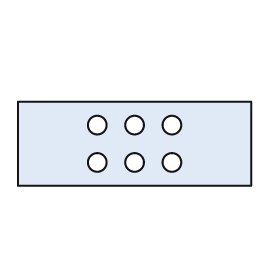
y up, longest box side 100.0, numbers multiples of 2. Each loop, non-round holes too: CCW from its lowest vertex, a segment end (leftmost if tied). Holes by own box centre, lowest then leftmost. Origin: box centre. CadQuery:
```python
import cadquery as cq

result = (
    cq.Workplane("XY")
    .moveTo(-50.0, -18.0)
    .lineTo(50.0, -18.0)
    .lineTo(50.0, 18.0)
    .lineTo(-50.0, 18.0)
    .close()
    .moveTo(-16.0, -8.0)
    .circle(4.0)
    .moveTo(0.0, -8.0)
    .circle(4.0)
    .moveTo(16.0, -8.0)
    .circle(4.0)
    .moveTo(-16.0, 8.0)
    .circle(4.0)
    .moveTo(0.0, 8.0)
    .circle(4.0)
    .moveTo(16.0, 8.0)
    .circle(4.0)
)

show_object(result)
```